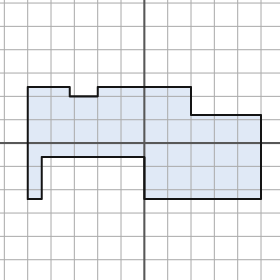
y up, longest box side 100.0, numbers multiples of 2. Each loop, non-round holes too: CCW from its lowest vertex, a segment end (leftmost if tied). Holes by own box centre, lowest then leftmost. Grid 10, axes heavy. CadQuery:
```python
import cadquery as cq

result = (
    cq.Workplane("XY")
    .moveTo(-50.0, -24.0)
    .lineTo(-44.0, -24.0)
    .lineTo(-44.0, -6.0)
    .lineTo(0.0, -6.0)
    .lineTo(0.0, -24.0)
    .lineTo(50.0, -24.0)
    .lineTo(50.0, 12.0)
    .lineTo(20.0, 12.0)
    .lineTo(20.0, 24.0)
    .lineTo(-20.0, 24.0)
    .lineTo(-20.0, 20.0)
    .lineTo(-32.0, 20.0)
    .lineTo(-32.0, 24.0)
    .lineTo(-50.0, 24.0)
    .close()
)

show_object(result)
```